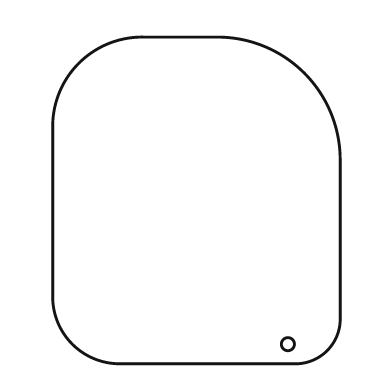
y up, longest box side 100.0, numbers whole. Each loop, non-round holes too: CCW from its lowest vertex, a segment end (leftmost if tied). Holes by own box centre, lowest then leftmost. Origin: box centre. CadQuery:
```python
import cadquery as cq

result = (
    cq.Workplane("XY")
    .moveTo(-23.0, -50.0)
    .lineTo(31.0, -50.0)
    .threePointArc((40.0, -46.0), (44.0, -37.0))
    .lineTo(44.0, 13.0)
    .threePointArc((33.0, 39.0), (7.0, 50.0))
    .lineTo(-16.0, 50.0)
    .threePointArc((-36.0, 42.0), (-44.0, 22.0))
    .lineTo(-44.0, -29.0)
    .threePointArc((-38.0, -44.0), (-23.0, -50.0))
    .close()
    .moveTo(28.0, -44.0)
    .circle(2.0)
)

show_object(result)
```